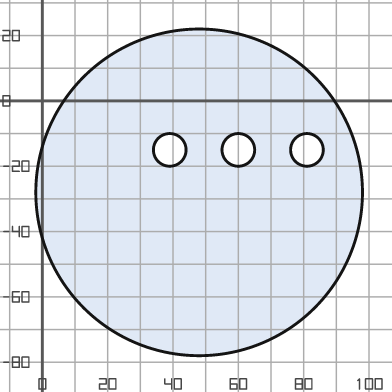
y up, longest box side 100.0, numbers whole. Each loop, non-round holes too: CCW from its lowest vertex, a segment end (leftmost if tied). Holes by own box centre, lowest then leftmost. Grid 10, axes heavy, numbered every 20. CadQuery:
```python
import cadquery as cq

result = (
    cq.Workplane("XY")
    .moveTo(48.0, -28.0)
    .circle(50.0)
    .moveTo(39.0, -15.0)
    .circle(5.0)
    .moveTo(60.0, -15.0)
    .circle(5.0)
    .moveTo(81.0, -15.0)
    .circle(5.0)
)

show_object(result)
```